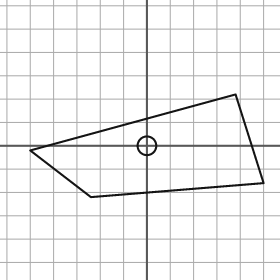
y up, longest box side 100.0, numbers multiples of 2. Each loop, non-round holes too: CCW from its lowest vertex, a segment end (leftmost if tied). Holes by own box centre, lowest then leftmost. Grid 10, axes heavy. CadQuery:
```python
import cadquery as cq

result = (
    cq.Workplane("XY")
    .moveTo(-24.0, -22.0)
    .lineTo(50.0, -16.0)
    .lineTo(38.0, 22.0)
    .lineTo(-50.0, -2.0)
    .close()
    .moveTo(0.0, 0.0)
    .circle(4.0)
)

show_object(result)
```